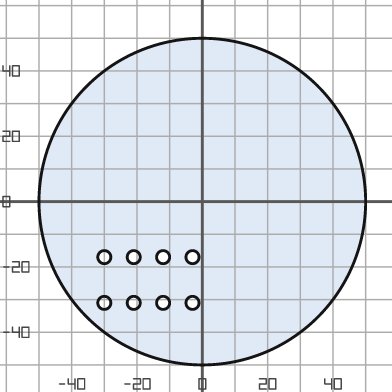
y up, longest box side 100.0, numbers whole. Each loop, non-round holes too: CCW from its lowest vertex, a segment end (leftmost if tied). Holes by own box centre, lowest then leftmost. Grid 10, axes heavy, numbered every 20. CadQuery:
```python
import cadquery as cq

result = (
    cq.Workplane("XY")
    .moveTo(0.0, 0.0)
    .circle(50.0)
    .moveTo(-30.0, -31.0)
    .circle(2.0)
    .moveTo(-21.0, -31.0)
    .circle(2.0)
    .moveTo(-12.0, -31.0)
    .circle(2.0)
    .moveTo(-3.0, -31.0)
    .circle(2.0)
    .moveTo(-30.0, -17.0)
    .circle(2.0)
    .moveTo(-21.0, -17.0)
    .circle(2.0)
    .moveTo(-12.0, -17.0)
    .circle(2.0)
    .moveTo(-3.0, -17.0)
    .circle(2.0)
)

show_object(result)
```